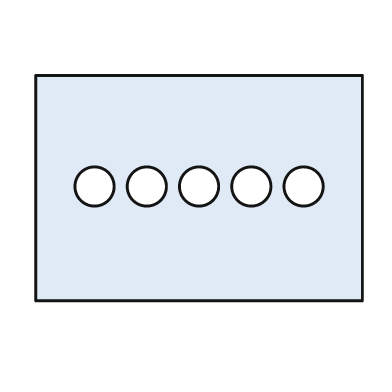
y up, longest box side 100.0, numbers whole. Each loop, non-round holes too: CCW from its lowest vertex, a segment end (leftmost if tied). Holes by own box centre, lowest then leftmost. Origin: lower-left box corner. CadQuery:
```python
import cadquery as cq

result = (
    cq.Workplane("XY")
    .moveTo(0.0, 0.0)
    .lineTo(100.0, 0.0)
    .lineTo(100.0, 69.0)
    .lineTo(0.0, 69.0)
    .close()
    .moveTo(18.0, 35.0)
    .circle(6.0)
    .moveTo(34.0, 35.0)
    .circle(6.0)
    .moveTo(50.0, 35.0)
    .circle(6.0)
    .moveTo(66.0, 35.0)
    .circle(6.0)
    .moveTo(82.0, 35.0)
    .circle(6.0)
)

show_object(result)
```